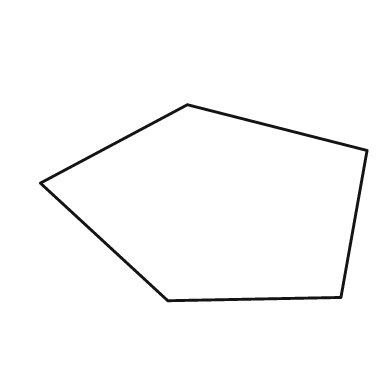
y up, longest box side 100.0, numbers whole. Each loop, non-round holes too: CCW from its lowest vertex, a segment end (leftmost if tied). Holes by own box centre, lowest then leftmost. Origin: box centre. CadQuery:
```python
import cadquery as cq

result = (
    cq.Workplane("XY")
    .moveTo(-11.0, -30.0)
    .lineTo(42.0, -29.0)
    .lineTo(50.0, 16.0)
    .lineTo(-5.0, 30.0)
    .lineTo(-50.0, 6.0)
    .close()
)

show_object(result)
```